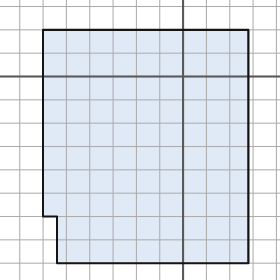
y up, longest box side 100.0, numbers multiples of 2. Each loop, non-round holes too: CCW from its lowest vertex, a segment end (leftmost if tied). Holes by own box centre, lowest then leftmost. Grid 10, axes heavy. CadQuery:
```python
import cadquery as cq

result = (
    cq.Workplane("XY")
    .moveTo(-54.0, -80.0)
    .lineTo(28.0, -80.0)
    .lineTo(28.0, 20.0)
    .lineTo(-60.0, 20.0)
    .lineTo(-60.0, -60.0)
    .lineTo(-54.0, -60.0)
    .close()
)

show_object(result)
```